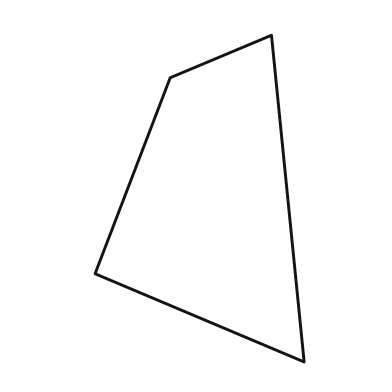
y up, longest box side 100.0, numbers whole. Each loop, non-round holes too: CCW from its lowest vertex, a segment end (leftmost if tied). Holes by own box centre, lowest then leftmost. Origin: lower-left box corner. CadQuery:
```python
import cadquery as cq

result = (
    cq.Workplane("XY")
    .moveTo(64.0, 0.0)
    .lineTo(54.0, 100.0)
    .lineTo(23.0, 87.0)
    .lineTo(0.0, 27.0)
    .close()
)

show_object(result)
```